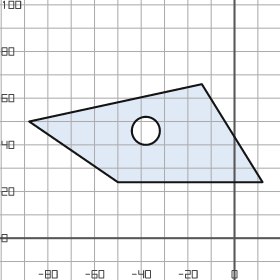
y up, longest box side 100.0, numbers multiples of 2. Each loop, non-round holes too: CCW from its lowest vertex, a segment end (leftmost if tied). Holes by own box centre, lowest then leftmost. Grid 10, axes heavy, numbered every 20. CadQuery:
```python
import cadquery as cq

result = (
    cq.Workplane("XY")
    .moveTo(-50.0, 24.0)
    .lineTo(12.0, 24.0)
    .lineTo(-14.0, 66.0)
    .lineTo(-88.0, 50.0)
    .close()
    .moveTo(-38.0, 46.0)
    .circle(6.0)
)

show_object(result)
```